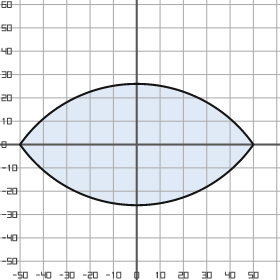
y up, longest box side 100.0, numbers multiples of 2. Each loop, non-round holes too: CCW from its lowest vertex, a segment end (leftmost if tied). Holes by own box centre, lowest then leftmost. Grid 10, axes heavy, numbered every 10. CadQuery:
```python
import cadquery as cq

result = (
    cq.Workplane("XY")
    .moveTo(-50.0, 0.0)
    .threePointArc((0.0, -26.0), (50.0, 0.0))
    .threePointArc((0.0, 26.0), (-50.0, 0.0))
    .close()
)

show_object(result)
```